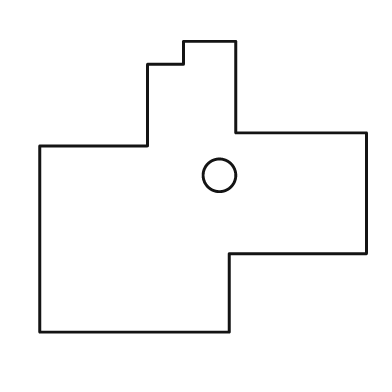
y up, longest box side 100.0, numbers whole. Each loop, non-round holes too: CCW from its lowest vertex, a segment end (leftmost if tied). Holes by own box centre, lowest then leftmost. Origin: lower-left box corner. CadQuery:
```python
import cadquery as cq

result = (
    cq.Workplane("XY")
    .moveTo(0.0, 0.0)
    .lineTo(58.0, 0.0)
    .lineTo(58.0, 24.0)
    .lineTo(100.0, 24.0)
    .lineTo(100.0, 61.0)
    .lineTo(60.0, 61.0)
    .lineTo(60.0, 89.0)
    .lineTo(44.0, 89.0)
    .lineTo(44.0, 82.0)
    .lineTo(33.0, 82.0)
    .lineTo(33.0, 57.0)
    .lineTo(0.0, 57.0)
    .close()
    .moveTo(55.0, 48.0)
    .circle(5.0)
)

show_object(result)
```